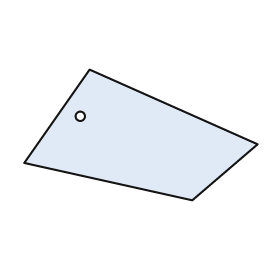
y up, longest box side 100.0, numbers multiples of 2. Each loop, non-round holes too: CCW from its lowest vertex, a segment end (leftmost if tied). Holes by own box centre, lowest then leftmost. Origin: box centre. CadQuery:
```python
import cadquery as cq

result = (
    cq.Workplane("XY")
    .moveTo(22.0, -28.0)
    .lineTo(50.0, -4.0)
    .lineTo(-22.0, 28.0)
    .lineTo(-50.0, -12.0)
    .close()
    .moveTo(-26.0, 8.0)
    .circle(2.0)
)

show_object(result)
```